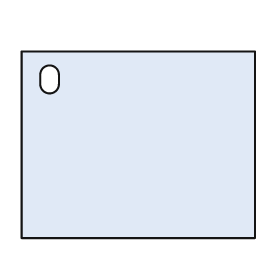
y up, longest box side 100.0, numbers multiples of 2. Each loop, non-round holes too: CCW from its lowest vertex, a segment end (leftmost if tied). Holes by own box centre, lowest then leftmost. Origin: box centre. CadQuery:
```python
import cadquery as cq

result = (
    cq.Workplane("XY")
    .moveTo(-50.0, -40.0)
    .lineTo(50.0, -40.0)
    .lineTo(50.0, 40.0)
    .lineTo(-50.0, 40.0)
    .close()
    .moveTo(-42.0, 26.0)
    .threePointArc((-38.0, 22.0), (-34.0, 26.0))
    .lineTo(-34.0, 30.0)
    .threePointArc((-38.0, 34.0), (-42.0, 30.0))
    .close()
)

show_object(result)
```